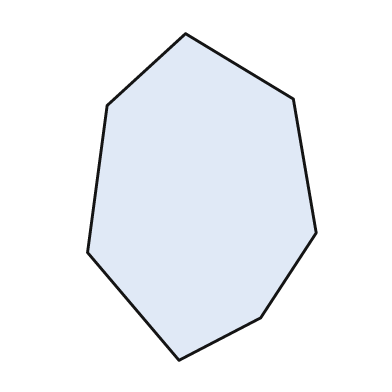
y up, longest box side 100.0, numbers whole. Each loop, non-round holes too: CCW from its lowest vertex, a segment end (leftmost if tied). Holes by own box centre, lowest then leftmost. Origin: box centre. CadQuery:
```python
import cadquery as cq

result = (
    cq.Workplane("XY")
    .moveTo(-7.0, -50.0)
    .lineTo(18.0, -37.0)
    .lineTo(35.0, -11.0)
    .lineTo(28.0, 30.0)
    .lineTo(-5.0, 50.0)
    .lineTo(-29.0, 28.0)
    .lineTo(-35.0, -17.0)
    .close()
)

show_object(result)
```